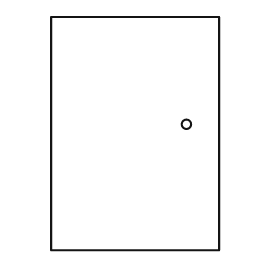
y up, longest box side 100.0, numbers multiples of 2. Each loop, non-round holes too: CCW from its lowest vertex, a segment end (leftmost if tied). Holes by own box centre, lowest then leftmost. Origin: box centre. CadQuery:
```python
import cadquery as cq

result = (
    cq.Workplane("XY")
    .moveTo(-36.0, -50.0)
    .lineTo(36.0, -50.0)
    .lineTo(36.0, 50.0)
    .lineTo(-36.0, 50.0)
    .close()
    .moveTo(22.0, 4.0)
    .circle(2.0)
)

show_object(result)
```